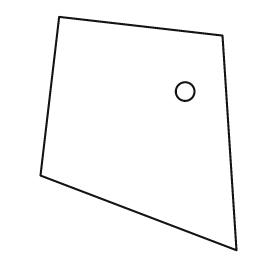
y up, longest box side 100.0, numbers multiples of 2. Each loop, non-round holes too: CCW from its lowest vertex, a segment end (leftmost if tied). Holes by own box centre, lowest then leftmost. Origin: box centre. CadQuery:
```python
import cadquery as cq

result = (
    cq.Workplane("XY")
    .moveTo(42.0, -50.0)
    .lineTo(36.0, 42.0)
    .lineTo(-34.0, 50.0)
    .lineTo(-42.0, -18.0)
    .close()
    .moveTo(20.0, 18.0)
    .circle(4.0)
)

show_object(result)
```